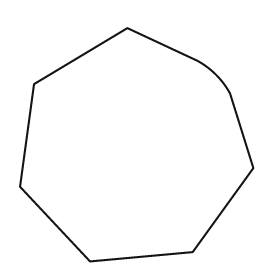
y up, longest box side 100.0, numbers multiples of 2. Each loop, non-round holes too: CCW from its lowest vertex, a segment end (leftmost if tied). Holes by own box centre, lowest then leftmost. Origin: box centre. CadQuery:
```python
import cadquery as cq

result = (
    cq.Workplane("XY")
    .moveTo(-20.0, -50.0)
    .lineTo(24.0, -46.0)
    .lineTo(50.0, -10.0)
    .lineTo(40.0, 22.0)
    .threePointArc((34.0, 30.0), (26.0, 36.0))
    .lineTo(-4.0, 50.0)
    .lineTo(-44.0, 26.0)
    .lineTo(-50.0, -18.0)
    .close()
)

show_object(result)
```